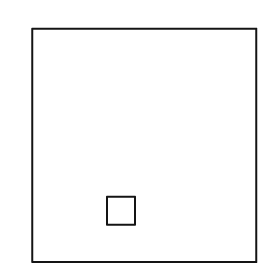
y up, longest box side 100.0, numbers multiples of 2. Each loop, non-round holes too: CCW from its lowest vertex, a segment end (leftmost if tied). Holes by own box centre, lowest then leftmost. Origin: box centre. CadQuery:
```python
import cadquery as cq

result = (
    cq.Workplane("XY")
    .moveTo(-48.0, -50.0)
    .lineTo(48.0, -50.0)
    .lineTo(48.0, 50.0)
    .lineTo(-48.0, 50.0)
    .close()
    .moveTo(-16.0, -34.0)
    .lineTo(-4.0, -34.0)
    .lineTo(-4.0, -22.0)
    .lineTo(-16.0, -22.0)
    .close()
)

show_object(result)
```